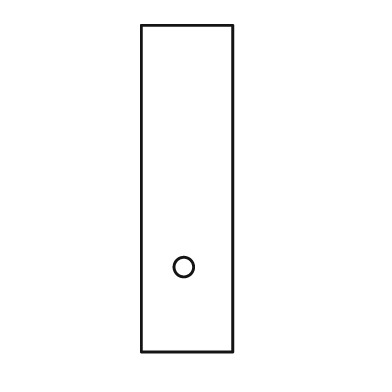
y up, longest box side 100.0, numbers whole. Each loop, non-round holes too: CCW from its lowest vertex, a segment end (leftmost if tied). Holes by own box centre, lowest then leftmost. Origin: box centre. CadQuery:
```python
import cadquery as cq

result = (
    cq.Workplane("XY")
    .moveTo(-14.0, -50.0)
    .lineTo(14.0, -50.0)
    .lineTo(14.0, 50.0)
    .lineTo(-14.0, 50.0)
    .close()
    .moveTo(-1.0, -24.0)
    .circle(3.0)
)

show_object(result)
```